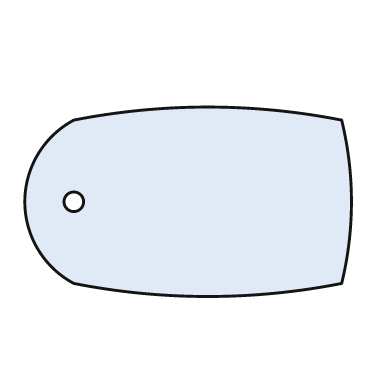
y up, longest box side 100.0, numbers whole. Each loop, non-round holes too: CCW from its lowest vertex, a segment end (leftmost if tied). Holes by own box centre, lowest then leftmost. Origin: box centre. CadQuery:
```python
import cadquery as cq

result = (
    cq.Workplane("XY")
    .moveTo(-35.0, -25.0)
    .threePointArc((6.0, -29.0), (47.0, -25.0))
    .threePointArc((50.0, 0.0), (47.0, 25.0))
    .threePointArc((6.0, 29.0), (-35.0, 25.0))
    .threePointArc((-50.0, 0.0), (-35.0, -25.0))
    .close()
    .moveTo(-35.0, 0.0)
    .circle(3.0)
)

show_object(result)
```